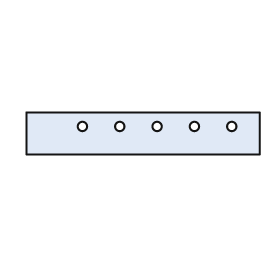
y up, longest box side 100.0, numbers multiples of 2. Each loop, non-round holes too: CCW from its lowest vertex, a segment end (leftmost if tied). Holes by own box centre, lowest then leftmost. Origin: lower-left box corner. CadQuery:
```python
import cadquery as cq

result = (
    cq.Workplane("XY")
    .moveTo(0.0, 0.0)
    .lineTo(100.0, 0.0)
    .lineTo(100.0, 18.0)
    .lineTo(0.0, 18.0)
    .close()
    .moveTo(24.0, 12.0)
    .circle(2.0)
    .moveTo(40.0, 12.0)
    .circle(2.0)
    .moveTo(56.0, 12.0)
    .circle(2.0)
    .moveTo(72.0, 12.0)
    .circle(2.0)
    .moveTo(88.0, 12.0)
    .circle(2.0)
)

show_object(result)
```